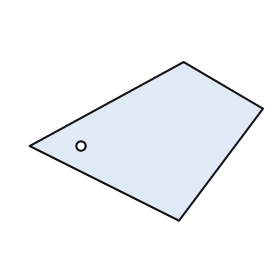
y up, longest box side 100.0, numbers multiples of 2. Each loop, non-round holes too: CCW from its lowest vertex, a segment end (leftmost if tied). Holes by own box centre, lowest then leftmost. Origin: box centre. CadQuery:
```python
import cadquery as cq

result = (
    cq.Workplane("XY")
    .moveTo(14.0, -34.0)
    .lineTo(50.0, 14.0)
    .lineTo(16.0, 34.0)
    .lineTo(-50.0, -2.0)
    .close()
    .moveTo(-28.0, -2.0)
    .circle(2.0)
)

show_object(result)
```